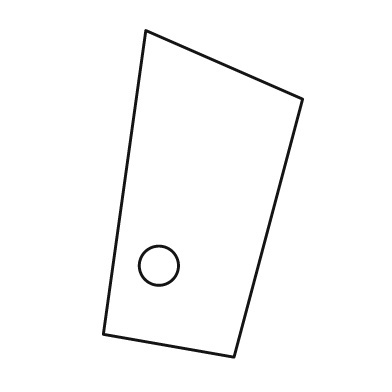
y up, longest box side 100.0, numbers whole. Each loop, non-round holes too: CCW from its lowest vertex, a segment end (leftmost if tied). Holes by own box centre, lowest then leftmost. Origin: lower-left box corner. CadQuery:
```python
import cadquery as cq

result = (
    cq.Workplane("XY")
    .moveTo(40.0, 0.0)
    .lineTo(61.0, 79.0)
    .lineTo(13.0, 100.0)
    .lineTo(0.0, 7.0)
    .close()
    .moveTo(17.0, 28.0)
    .circle(6.0)
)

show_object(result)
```